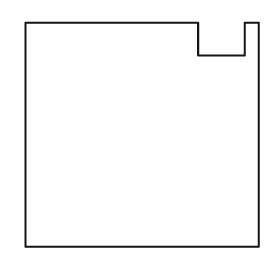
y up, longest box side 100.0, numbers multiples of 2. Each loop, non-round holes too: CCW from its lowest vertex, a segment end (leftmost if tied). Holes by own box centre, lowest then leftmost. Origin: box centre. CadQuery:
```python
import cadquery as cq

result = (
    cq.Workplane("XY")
    .moveTo(-50.0, -48.0)
    .lineTo(50.0, -48.0)
    .lineTo(50.0, 48.0)
    .lineTo(44.0, 48.0)
    .lineTo(44.0, 34.0)
    .lineTo(24.0, 34.0)
    .lineTo(24.0, 48.0)
    .lineTo(-50.0, 48.0)
    .close()
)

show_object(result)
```